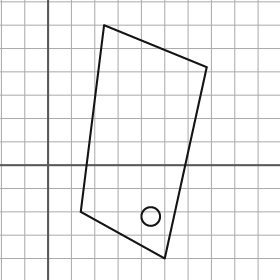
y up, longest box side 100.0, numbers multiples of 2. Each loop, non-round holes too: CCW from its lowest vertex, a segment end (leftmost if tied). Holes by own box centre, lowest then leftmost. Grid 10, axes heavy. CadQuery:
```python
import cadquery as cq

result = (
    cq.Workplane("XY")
    .moveTo(50.0, -40.0)
    .lineTo(68.0, 42.0)
    .lineTo(24.0, 60.0)
    .lineTo(14.0, -20.0)
    .close()
    .moveTo(44.0, -22.0)
    .circle(4.0)
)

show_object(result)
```